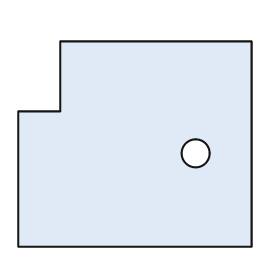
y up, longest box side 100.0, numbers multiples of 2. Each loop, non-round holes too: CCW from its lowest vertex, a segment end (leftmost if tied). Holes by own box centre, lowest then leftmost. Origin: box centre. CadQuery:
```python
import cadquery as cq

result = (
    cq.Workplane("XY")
    .moveTo(-50.0, -44.0)
    .lineTo(50.0, -44.0)
    .lineTo(50.0, 44.0)
    .lineTo(-32.0, 44.0)
    .lineTo(-32.0, 14.0)
    .lineTo(-50.0, 14.0)
    .close()
    .moveTo(26.0, -4.0)
    .circle(6.0)
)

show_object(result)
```